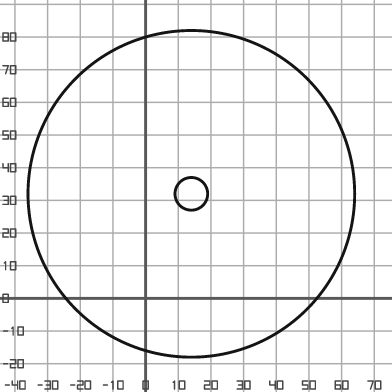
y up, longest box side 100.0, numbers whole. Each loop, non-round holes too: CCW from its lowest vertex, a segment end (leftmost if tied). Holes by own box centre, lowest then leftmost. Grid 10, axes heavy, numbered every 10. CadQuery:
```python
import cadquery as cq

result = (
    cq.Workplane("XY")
    .moveTo(14.0, 32.0)
    .circle(50.0)
    .moveTo(14.0, 32.0)
    .circle(5.0)
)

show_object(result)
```